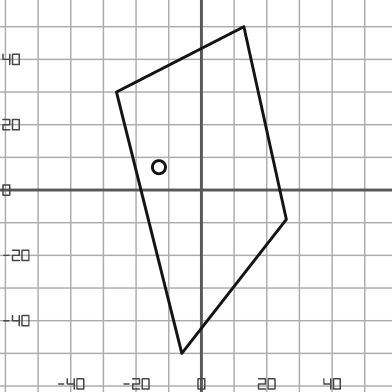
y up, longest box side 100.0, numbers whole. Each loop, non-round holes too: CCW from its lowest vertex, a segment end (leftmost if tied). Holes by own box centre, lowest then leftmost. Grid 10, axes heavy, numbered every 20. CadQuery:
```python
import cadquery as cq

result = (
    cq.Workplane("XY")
    .moveTo(-6.0, -50.0)
    .lineTo(26.0, -9.0)
    .lineTo(13.0, 50.0)
    .lineTo(-26.0, 30.0)
    .close()
    .moveTo(-13.0, 7.0)
    .circle(2.0)
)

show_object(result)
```